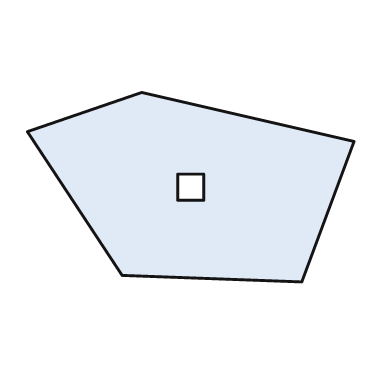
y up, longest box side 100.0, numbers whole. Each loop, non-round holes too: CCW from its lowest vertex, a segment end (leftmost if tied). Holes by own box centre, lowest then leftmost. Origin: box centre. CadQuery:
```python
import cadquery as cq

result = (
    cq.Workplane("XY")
    .moveTo(34.0, -29.0)
    .lineTo(50.0, 14.0)
    .lineTo(-15.0, 29.0)
    .lineTo(-50.0, 17.0)
    .lineTo(-21.0, -27.0)
    .close()
    .moveTo(-4.0, -4.0)
    .lineTo(4.0, -4.0)
    .lineTo(4.0, 4.0)
    .lineTo(-4.0, 4.0)
    .close()
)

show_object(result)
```